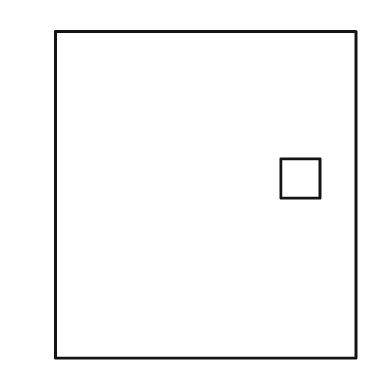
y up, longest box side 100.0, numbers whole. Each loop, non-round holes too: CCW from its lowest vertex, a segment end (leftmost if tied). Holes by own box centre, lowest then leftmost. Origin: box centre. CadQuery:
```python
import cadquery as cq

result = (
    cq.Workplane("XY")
    .moveTo(-46.0, -50.0)
    .lineTo(46.0, -50.0)
    .lineTo(46.0, 50.0)
    .lineTo(-46.0, 50.0)
    .close()
    .moveTo(23.0, -1.0)
    .lineTo(35.0, -1.0)
    .lineTo(35.0, 11.0)
    .lineTo(23.0, 11.0)
    .close()
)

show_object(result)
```